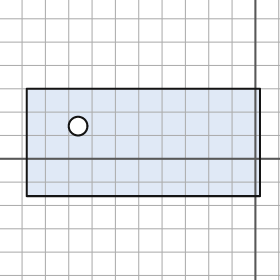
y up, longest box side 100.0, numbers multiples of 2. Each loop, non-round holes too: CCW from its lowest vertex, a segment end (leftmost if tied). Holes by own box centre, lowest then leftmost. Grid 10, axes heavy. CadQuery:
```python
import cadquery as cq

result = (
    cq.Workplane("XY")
    .moveTo(-98.0, -16.0)
    .lineTo(2.0, -16.0)
    .lineTo(2.0, 30.0)
    .lineTo(-98.0, 30.0)
    .close()
    .moveTo(-76.0, 14.0)
    .circle(4.0)
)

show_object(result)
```